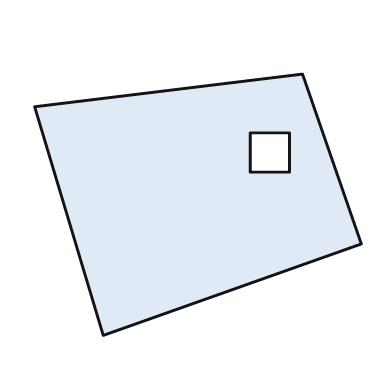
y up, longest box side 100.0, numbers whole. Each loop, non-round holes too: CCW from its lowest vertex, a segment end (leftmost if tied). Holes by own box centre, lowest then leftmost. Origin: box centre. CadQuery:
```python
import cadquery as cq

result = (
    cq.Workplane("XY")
    .moveTo(-29.0, -40.0)
    .lineTo(50.0, -12.0)
    .lineTo(32.0, 40.0)
    .lineTo(-50.0, 30.0)
    .close()
    .moveTo(16.0, 10.0)
    .lineTo(28.0, 10.0)
    .lineTo(28.0, 22.0)
    .lineTo(16.0, 22.0)
    .close()
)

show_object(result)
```